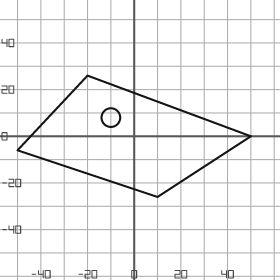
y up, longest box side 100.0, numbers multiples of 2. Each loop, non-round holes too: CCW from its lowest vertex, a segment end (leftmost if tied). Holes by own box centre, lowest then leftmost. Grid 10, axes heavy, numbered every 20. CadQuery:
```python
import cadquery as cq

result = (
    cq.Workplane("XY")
    .moveTo(10.0, -26.0)
    .lineTo(50.0, 0.0)
    .lineTo(-20.0, 26.0)
    .lineTo(-50.0, -6.0)
    .close()
    .moveTo(-10.0, 8.0)
    .circle(4.0)
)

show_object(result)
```